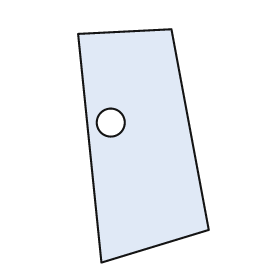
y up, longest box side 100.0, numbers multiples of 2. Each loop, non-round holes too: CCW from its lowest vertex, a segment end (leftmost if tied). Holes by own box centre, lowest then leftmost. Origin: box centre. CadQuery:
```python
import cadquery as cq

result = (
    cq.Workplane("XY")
    .moveTo(-18.0, -50.0)
    .lineTo(28.0, -36.0)
    .lineTo(12.0, 50.0)
    .lineTo(-28.0, 48.0)
    .close()
    .moveTo(-14.0, 10.0)
    .circle(6.0)
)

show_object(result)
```